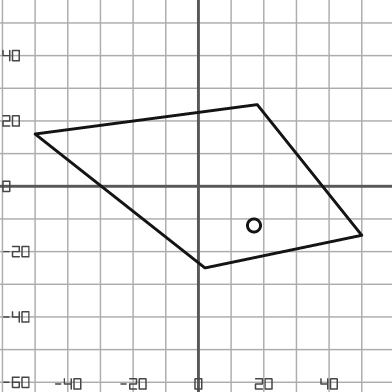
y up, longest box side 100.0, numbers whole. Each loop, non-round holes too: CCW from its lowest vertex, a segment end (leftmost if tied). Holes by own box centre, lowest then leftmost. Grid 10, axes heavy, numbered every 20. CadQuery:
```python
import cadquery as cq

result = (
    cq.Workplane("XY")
    .moveTo(2.0, -25.0)
    .lineTo(50.0, -15.0)
    .lineTo(18.0, 25.0)
    .lineTo(-50.0, 16.0)
    .close()
    .moveTo(17.0, -12.0)
    .circle(2.0)
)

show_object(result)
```